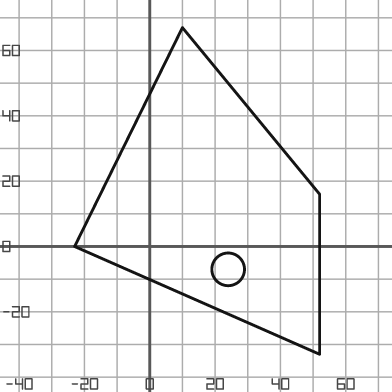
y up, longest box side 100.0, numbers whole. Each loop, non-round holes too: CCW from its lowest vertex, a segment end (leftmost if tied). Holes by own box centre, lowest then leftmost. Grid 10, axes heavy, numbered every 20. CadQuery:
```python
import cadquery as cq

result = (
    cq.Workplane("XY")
    .moveTo(52.0, -33.0)
    .lineTo(52.0, 16.0)
    .lineTo(10.0, 67.0)
    .lineTo(-23.0, 0.0)
    .close()
    .moveTo(24.0, -7.0)
    .circle(5.0)
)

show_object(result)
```